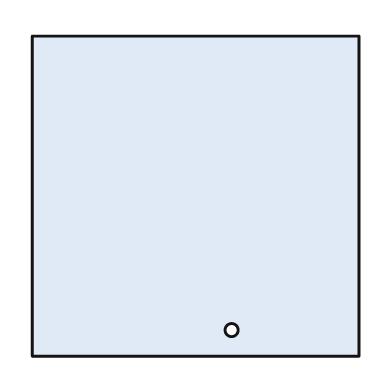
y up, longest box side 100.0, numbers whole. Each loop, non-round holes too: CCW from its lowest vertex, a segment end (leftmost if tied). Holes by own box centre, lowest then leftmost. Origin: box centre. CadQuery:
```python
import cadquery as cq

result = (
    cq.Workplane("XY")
    .moveTo(-50.0, -49.0)
    .lineTo(50.0, -49.0)
    .lineTo(50.0, 49.0)
    .lineTo(-50.0, 49.0)
    .close()
    .moveTo(11.0, -41.0)
    .circle(2.0)
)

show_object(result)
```